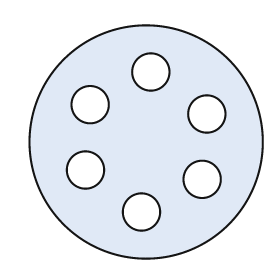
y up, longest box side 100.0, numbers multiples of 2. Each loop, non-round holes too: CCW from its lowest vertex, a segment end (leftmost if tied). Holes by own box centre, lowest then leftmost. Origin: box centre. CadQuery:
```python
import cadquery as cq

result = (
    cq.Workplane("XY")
    .moveTo(0.0, 0.0)
    .circle(50.0)
    .moveTo(-2.0, -30.0)
    .circle(8.0)
    .moveTo(24.0, -16.0)
    .circle(8.0)
    .moveTo(-26.0, -12.0)
    .circle(8.0)
    .moveTo(26.0, 12.0)
    .circle(8.0)
    .moveTo(-24.0, 16.0)
    .circle(8.0)
    .moveTo(2.0, 30.0)
    .circle(8.0)
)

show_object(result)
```